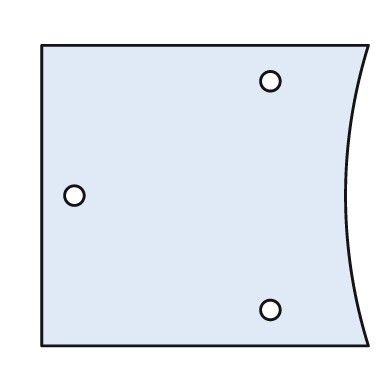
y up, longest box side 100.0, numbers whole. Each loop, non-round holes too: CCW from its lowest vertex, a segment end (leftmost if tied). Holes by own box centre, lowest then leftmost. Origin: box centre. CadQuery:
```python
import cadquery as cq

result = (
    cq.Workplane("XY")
    .moveTo(-50.0, -46.0)
    .lineTo(50.0, -46.0)
    .threePointArc((43.0, 0.0), (50.0, 46.0))
    .lineTo(-50.0, 46.0)
    .close()
    .moveTo(20.0, -35.0)
    .circle(3.0)
    .moveTo(-40.0, 0.0)
    .circle(3.0)
    .moveTo(20.0, 35.0)
    .circle(3.0)
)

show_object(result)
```